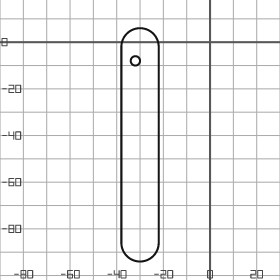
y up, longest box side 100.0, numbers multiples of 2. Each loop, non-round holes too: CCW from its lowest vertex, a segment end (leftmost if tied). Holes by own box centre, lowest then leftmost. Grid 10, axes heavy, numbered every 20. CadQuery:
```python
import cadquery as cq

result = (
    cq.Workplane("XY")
    .moveTo(-38.0, -86.0)
    .threePointArc((-30.0, -94.0), (-22.0, -86.0))
    .lineTo(-22.0, -2.0)
    .threePointArc((-30.0, 6.0), (-38.0, -2.0))
    .close()
    .moveTo(-32.0, -8.0)
    .circle(2.0)
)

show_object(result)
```